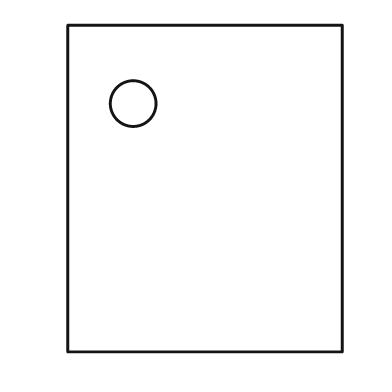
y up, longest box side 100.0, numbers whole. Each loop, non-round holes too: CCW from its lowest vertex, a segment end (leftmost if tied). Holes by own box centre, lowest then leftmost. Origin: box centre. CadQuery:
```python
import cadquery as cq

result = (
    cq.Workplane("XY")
    .moveTo(-42.0, -50.0)
    .lineTo(42.0, -50.0)
    .lineTo(42.0, 50.0)
    .lineTo(-42.0, 50.0)
    .close()
    .moveTo(-22.0, 26.0)
    .circle(7.0)
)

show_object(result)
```